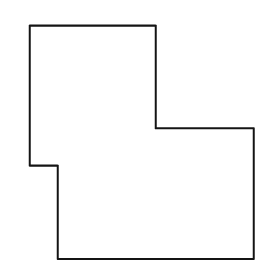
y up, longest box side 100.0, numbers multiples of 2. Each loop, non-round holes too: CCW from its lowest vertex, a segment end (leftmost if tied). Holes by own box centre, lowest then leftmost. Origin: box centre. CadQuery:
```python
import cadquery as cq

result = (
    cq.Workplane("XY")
    .moveTo(-36.0, -50.0)
    .lineTo(48.0, -50.0)
    .lineTo(48.0, 6.0)
    .lineTo(6.0, 6.0)
    .lineTo(6.0, 50.0)
    .lineTo(-48.0, 50.0)
    .lineTo(-48.0, -10.0)
    .lineTo(-36.0, -10.0)
    .close()
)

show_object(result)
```